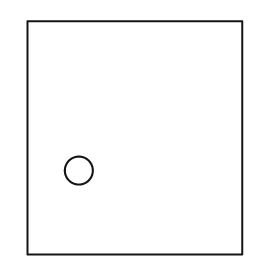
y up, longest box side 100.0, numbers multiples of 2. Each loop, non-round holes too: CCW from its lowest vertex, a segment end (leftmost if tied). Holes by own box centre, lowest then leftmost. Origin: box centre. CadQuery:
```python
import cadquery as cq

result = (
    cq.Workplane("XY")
    .moveTo(-46.0, -50.0)
    .lineTo(46.0, -50.0)
    .lineTo(46.0, 50.0)
    .lineTo(-46.0, 50.0)
    .close()
    .moveTo(-24.0, -14.0)
    .circle(6.0)
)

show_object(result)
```